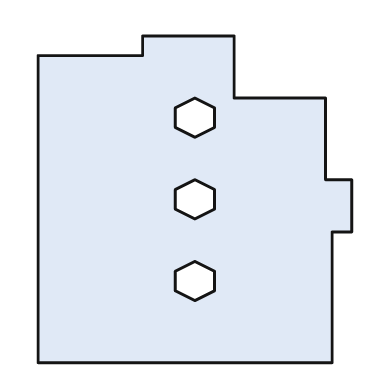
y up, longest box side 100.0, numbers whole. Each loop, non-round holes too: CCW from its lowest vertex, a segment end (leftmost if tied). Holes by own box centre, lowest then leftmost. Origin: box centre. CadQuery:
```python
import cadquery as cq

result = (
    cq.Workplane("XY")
    .moveTo(-48.0, -50.0)
    .lineTo(42.0, -50.0)
    .lineTo(42.0, -10.0)
    .lineTo(48.0, -10.0)
    .lineTo(48.0, 6.0)
    .lineTo(40.0, 6.0)
    .lineTo(40.0, 31.0)
    .lineTo(12.0, 31.0)
    .lineTo(12.0, 50.0)
    .lineTo(-16.0, 50.0)
    .lineTo(-16.0, 44.0)
    .lineTo(-48.0, 44.0)
    .close()
    .moveTo(0.0, -31.0)
    .lineTo(6.0, -28.0)
    .lineTo(6.0, -22.0)
    .lineTo(0.0, -19.0)
    .lineTo(-6.0, -22.0)
    .lineTo(-6.0, -28.0)
    .close()
    .moveTo(0.0, -6.0)
    .lineTo(6.0, -3.0)
    .lineTo(6.0, 3.0)
    .lineTo(0.0, 6.0)
    .lineTo(-6.0, 3.0)
    .lineTo(-6.0, -3.0)
    .close()
    .moveTo(0.0, 19.0)
    .lineTo(6.0, 22.0)
    .lineTo(6.0, 28.0)
    .lineTo(0.0, 31.0)
    .lineTo(-6.0, 28.0)
    .lineTo(-6.0, 22.0)
    .close()
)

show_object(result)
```